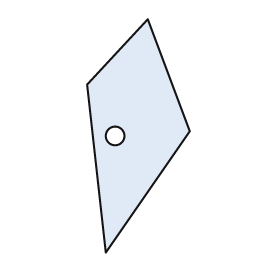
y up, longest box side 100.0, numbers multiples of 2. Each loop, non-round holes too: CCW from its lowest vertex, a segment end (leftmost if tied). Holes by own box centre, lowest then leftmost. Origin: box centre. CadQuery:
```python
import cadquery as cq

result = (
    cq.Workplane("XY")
    .moveTo(-14.0, -50.0)
    .lineTo(22.0, 2.0)
    .lineTo(4.0, 50.0)
    .lineTo(-22.0, 22.0)
    .close()
    .moveTo(-10.0, 0.0)
    .circle(4.0)
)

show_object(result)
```